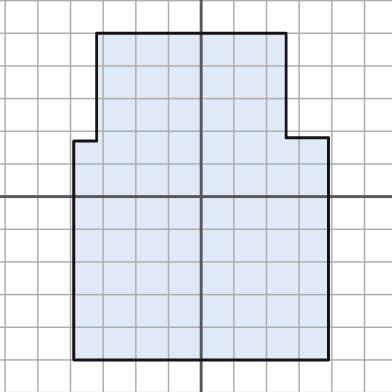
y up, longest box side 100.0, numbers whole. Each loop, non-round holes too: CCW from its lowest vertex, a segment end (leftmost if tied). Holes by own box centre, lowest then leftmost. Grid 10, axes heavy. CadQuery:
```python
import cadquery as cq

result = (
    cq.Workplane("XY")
    .moveTo(-39.0, -50.0)
    .lineTo(39.0, -50.0)
    .lineTo(39.0, 18.0)
    .lineTo(26.0, 18.0)
    .lineTo(26.0, 50.0)
    .lineTo(-32.0, 50.0)
    .lineTo(-32.0, 17.0)
    .lineTo(-39.0, 17.0)
    .close()
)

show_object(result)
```